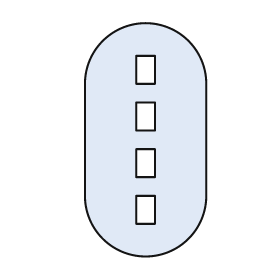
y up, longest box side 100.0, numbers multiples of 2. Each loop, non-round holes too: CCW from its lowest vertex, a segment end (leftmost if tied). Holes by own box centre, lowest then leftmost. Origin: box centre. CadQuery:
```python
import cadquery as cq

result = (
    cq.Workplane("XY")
    .moveTo(-26.0, -24.0)
    .threePointArc((0.0, -50.0), (26.0, -24.0))
    .lineTo(26.0, 24.0)
    .threePointArc((0.0, 50.0), (-26.0, 24.0))
    .close()
    .moveTo(-4.0, -36.0)
    .lineTo(4.0, -36.0)
    .lineTo(4.0, -24.0)
    .lineTo(-4.0, -24.0)
    .close()
    .moveTo(-4.0, -16.0)
    .lineTo(4.0, -16.0)
    .lineTo(4.0, -4.0)
    .lineTo(-4.0, -4.0)
    .close()
    .moveTo(-4.0, 4.0)
    .lineTo(4.0, 4.0)
    .lineTo(4.0, 16.0)
    .lineTo(-4.0, 16.0)
    .close()
    .moveTo(-4.0, 24.0)
    .lineTo(4.0, 24.0)
    .lineTo(4.0, 36.0)
    .lineTo(-4.0, 36.0)
    .close()
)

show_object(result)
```